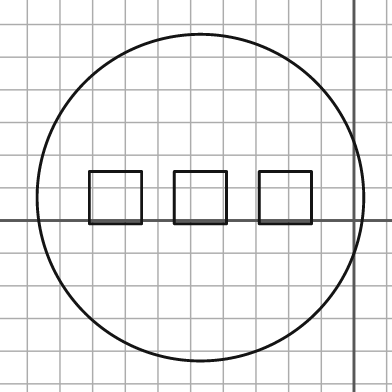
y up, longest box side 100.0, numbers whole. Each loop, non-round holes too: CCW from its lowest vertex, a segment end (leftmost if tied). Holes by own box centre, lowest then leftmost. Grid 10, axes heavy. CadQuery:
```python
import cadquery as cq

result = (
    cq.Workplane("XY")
    .moveTo(-47.0, 7.0)
    .circle(50.0)
    .moveTo(-81.0, -1.0)
    .lineTo(-65.0, -1.0)
    .lineTo(-65.0, 15.0)
    .lineTo(-81.0, 15.0)
    .close()
    .moveTo(-55.0, -1.0)
    .lineTo(-39.0, -1.0)
    .lineTo(-39.0, 15.0)
    .lineTo(-55.0, 15.0)
    .close()
    .moveTo(-29.0, -1.0)
    .lineTo(-13.0, -1.0)
    .lineTo(-13.0, 15.0)
    .lineTo(-29.0, 15.0)
    .close()
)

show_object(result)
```